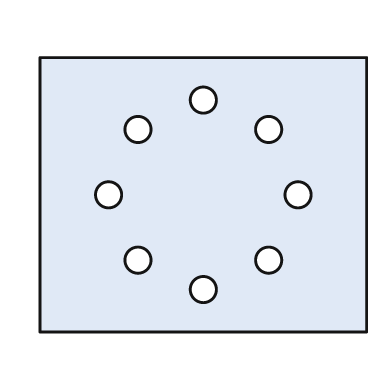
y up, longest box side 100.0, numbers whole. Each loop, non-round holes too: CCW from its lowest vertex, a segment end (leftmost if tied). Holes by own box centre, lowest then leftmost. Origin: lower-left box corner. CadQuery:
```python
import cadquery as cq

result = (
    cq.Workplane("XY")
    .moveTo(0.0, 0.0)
    .lineTo(100.0, 0.0)
    .lineTo(100.0, 84.0)
    .lineTo(0.0, 84.0)
    .close()
    .moveTo(50.0, 13.0)
    .circle(4.0)
    .moveTo(30.0, 22.0)
    .circle(4.0)
    .moveTo(70.0, 22.0)
    .circle(4.0)
    .moveTo(21.0, 42.0)
    .circle(4.0)
    .moveTo(79.0, 42.0)
    .circle(4.0)
    .moveTo(30.0, 62.0)
    .circle(4.0)
    .moveTo(70.0, 62.0)
    .circle(4.0)
    .moveTo(50.0, 71.0)
    .circle(4.0)
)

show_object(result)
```